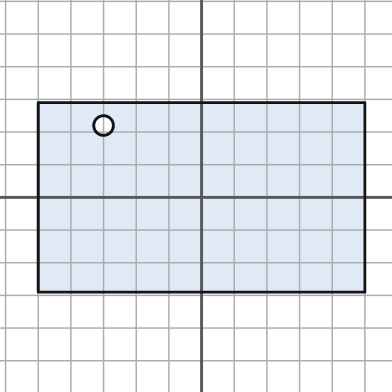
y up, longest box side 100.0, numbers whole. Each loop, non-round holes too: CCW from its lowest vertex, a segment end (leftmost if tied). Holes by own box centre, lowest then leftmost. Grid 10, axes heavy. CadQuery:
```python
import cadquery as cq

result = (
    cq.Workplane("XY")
    .moveTo(-50.0, -29.0)
    .lineTo(50.0, -29.0)
    .lineTo(50.0, 29.0)
    .lineTo(-50.0, 29.0)
    .close()
    .moveTo(-30.0, 22.0)
    .circle(3.0)
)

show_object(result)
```